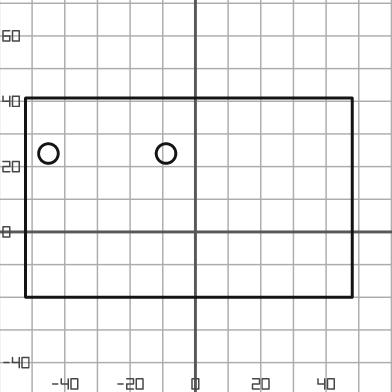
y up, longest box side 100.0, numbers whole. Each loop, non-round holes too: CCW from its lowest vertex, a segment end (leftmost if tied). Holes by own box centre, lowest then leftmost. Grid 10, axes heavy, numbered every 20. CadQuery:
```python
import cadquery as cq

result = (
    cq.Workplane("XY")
    .moveTo(-52.0, -20.0)
    .lineTo(48.0, -20.0)
    .lineTo(48.0, 41.0)
    .lineTo(-52.0, 41.0)
    .close()
    .moveTo(-45.0, 24.0)
    .circle(3.0)
    .moveTo(-9.0, 24.0)
    .circle(3.0)
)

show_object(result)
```